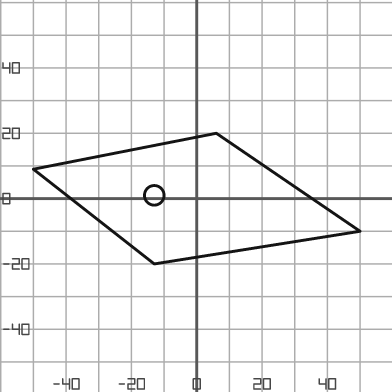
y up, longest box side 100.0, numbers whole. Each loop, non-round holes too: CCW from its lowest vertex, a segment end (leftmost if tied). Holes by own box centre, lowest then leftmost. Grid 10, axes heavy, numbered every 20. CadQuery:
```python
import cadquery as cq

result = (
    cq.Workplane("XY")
    .moveTo(-13.0, -20.0)
    .lineTo(50.0, -10.0)
    .lineTo(6.0, 20.0)
    .lineTo(-50.0, 9.0)
    .close()
    .moveTo(-13.0, 1.0)
    .circle(3.0)
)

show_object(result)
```